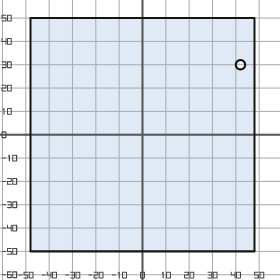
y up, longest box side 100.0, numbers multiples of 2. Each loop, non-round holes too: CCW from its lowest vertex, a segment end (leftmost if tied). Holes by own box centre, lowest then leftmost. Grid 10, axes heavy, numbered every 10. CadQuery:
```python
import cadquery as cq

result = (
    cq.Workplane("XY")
    .moveTo(-48.0, -50.0)
    .lineTo(48.0, -50.0)
    .lineTo(48.0, 50.0)
    .lineTo(-48.0, 50.0)
    .close()
    .moveTo(42.0, 30.0)
    .circle(2.0)
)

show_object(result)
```